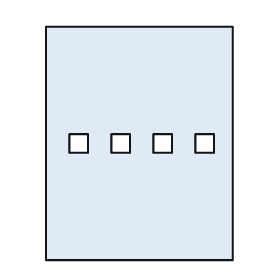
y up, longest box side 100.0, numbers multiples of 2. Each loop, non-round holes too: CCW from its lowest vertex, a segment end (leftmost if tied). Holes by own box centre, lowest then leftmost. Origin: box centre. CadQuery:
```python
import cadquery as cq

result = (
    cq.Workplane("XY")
    .moveTo(-40.0, -50.0)
    .lineTo(40.0, -50.0)
    .lineTo(40.0, 50.0)
    .lineTo(-40.0, 50.0)
    .close()
    .moveTo(-30.0, -4.0)
    .lineTo(-22.0, -4.0)
    .lineTo(-22.0, 4.0)
    .lineTo(-30.0, 4.0)
    .close()
    .moveTo(-12.0, -4.0)
    .lineTo(-4.0, -4.0)
    .lineTo(-4.0, 4.0)
    .lineTo(-12.0, 4.0)
    .close()
    .moveTo(6.0, -4.0)
    .lineTo(14.0, -4.0)
    .lineTo(14.0, 4.0)
    .lineTo(6.0, 4.0)
    .close()
    .moveTo(24.0, -4.0)
    .lineTo(32.0, -4.0)
    .lineTo(32.0, 4.0)
    .lineTo(24.0, 4.0)
    .close()
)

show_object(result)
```